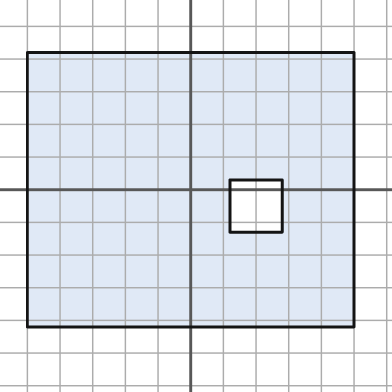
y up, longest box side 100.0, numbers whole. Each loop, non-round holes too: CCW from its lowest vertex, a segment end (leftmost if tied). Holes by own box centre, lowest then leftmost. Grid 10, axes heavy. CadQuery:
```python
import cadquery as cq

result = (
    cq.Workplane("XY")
    .moveTo(-50.0, -42.0)
    .lineTo(50.0, -42.0)
    .lineTo(50.0, 42.0)
    .lineTo(-50.0, 42.0)
    .close()
    .moveTo(12.0, -13.0)
    .lineTo(28.0, -13.0)
    .lineTo(28.0, 3.0)
    .lineTo(12.0, 3.0)
    .close()
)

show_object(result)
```